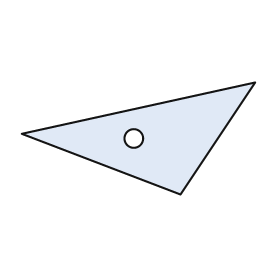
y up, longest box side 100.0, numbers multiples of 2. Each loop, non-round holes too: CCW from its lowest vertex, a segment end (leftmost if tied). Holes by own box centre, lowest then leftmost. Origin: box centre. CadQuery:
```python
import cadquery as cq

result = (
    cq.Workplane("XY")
    .moveTo(18.0, -24.0)
    .lineTo(50.0, 24.0)
    .lineTo(-50.0, 2.0)
    .close()
    .moveTo(-2.0, 0.0)
    .circle(4.0)
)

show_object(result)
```